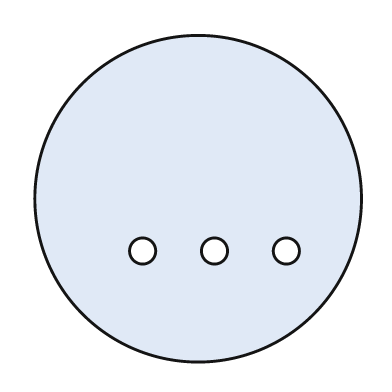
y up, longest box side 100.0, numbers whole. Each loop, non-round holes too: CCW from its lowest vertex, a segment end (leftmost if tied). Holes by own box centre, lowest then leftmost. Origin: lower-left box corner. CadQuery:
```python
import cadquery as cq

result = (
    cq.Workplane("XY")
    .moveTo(50.0, 50.0)
    .circle(50.0)
    .moveTo(33.0, 34.0)
    .circle(4.0)
    .moveTo(55.0, 34.0)
    .circle(4.0)
    .moveTo(77.0, 34.0)
    .circle(4.0)
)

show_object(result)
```